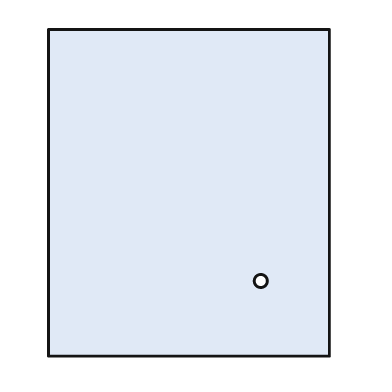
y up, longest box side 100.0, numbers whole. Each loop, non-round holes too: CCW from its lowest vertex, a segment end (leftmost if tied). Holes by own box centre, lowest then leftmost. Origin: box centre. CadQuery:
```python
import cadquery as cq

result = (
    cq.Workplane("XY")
    .moveTo(-43.0, -50.0)
    .lineTo(43.0, -50.0)
    .lineTo(43.0, 50.0)
    .lineTo(-43.0, 50.0)
    .close()
    .moveTo(22.0, -27.0)
    .circle(2.0)
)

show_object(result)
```